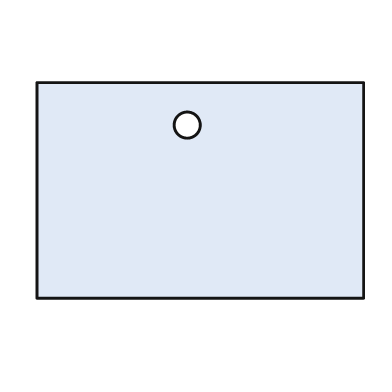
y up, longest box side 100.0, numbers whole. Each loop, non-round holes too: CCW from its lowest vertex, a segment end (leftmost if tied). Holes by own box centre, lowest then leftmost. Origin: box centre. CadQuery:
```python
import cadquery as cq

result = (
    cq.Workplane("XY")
    .moveTo(-50.0, -33.0)
    .lineTo(50.0, -33.0)
    .lineTo(50.0, 33.0)
    .lineTo(-50.0, 33.0)
    .close()
    .moveTo(-4.0, 20.0)
    .circle(4.0)
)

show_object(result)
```